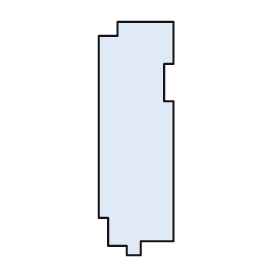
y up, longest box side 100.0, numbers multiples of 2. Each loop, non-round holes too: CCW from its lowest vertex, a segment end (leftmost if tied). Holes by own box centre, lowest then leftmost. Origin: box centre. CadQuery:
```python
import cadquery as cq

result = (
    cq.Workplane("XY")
    .moveTo(-4.0, -50.0)
    .lineTo(2.0, -50.0)
    .lineTo(2.0, -44.0)
    .lineTo(16.0, -44.0)
    .lineTo(16.0, 16.0)
    .lineTo(12.0, 16.0)
    .lineTo(12.0, 32.0)
    .lineTo(16.0, 32.0)
    .lineTo(16.0, 50.0)
    .lineTo(-8.0, 50.0)
    .lineTo(-8.0, 44.0)
    .lineTo(-16.0, 44.0)
    .lineTo(-16.0, -34.0)
    .lineTo(-12.0, -34.0)
    .lineTo(-12.0, -46.0)
    .lineTo(-4.0, -46.0)
    .close()
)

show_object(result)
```